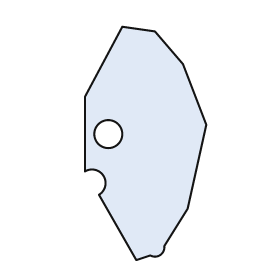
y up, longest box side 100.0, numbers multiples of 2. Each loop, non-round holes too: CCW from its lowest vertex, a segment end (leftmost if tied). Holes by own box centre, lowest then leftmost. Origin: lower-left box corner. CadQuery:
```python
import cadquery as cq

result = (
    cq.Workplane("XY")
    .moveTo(22.0, 0.0)
    .lineTo(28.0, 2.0)
    .threePointArc((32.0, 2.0), (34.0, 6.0))
    .lineTo(44.0, 22.0)
    .lineTo(52.0, 58.0)
    .lineTo(42.0, 84.0)
    .lineTo(30.0, 98.0)
    .lineTo(16.0, 100.0)
    .lineTo(0.0, 70.0)
    .lineTo(0.0, 38.0)
    .threePointArc((8.0, 36.0), (6.0, 28.0))
    .close()
    .moveTo(10.0, 54.0)
    .circle(6.0)
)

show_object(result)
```